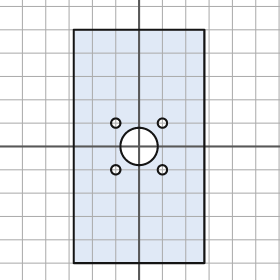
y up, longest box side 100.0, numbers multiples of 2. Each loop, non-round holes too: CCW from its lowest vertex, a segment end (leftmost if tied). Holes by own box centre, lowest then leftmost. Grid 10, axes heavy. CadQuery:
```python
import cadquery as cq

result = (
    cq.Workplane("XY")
    .moveTo(-28.0, -50.0)
    .lineTo(28.0, -50.0)
    .lineTo(28.0, 50.0)
    .lineTo(-28.0, 50.0)
    .close()
    .moveTo(-10.0, -10.0)
    .circle(2.0)
    .moveTo(10.0, -10.0)
    .circle(2.0)
    .moveTo(0.0, 0.0)
    .circle(8.0)
    .moveTo(-10.0, 10.0)
    .circle(2.0)
    .moveTo(10.0, 10.0)
    .circle(2.0)
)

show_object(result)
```